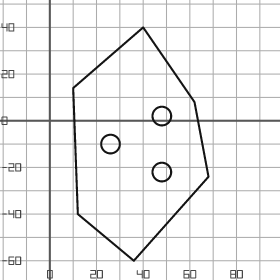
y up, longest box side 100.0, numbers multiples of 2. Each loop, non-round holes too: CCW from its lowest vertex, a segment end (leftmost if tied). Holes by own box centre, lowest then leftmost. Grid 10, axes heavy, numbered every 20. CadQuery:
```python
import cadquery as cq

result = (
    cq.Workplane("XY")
    .moveTo(36.0, -60.0)
    .lineTo(68.0, -24.0)
    .lineTo(62.0, 8.0)
    .lineTo(40.0, 40.0)
    .lineTo(10.0, 14.0)
    .lineTo(12.0, -40.0)
    .close()
    .moveTo(48.0, -22.0)
    .circle(4.0)
    .moveTo(26.0, -10.0)
    .circle(4.0)
    .moveTo(48.0, 2.0)
    .circle(4.0)
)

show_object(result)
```